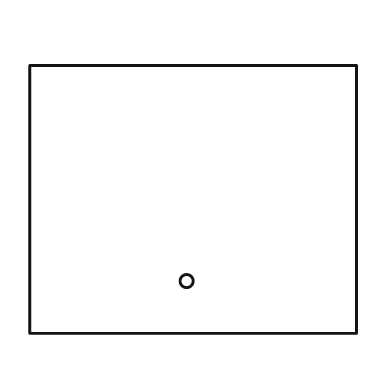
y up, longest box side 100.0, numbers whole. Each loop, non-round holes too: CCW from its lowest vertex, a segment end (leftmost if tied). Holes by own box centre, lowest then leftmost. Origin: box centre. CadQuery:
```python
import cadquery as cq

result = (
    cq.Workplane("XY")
    .moveTo(-50.0, -41.0)
    .lineTo(50.0, -41.0)
    .lineTo(50.0, 41.0)
    .lineTo(-50.0, 41.0)
    .close()
    .moveTo(-2.0, -25.0)
    .circle(2.0)
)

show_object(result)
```